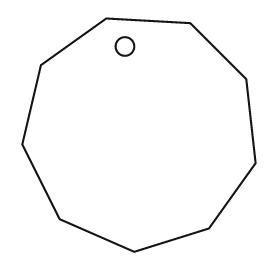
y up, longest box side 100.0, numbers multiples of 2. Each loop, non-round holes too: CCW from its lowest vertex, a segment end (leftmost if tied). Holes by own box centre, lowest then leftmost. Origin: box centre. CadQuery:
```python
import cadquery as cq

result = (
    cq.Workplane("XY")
    .moveTo(-2.0, -50.0)
    .lineTo(30.0, -40.0)
    .lineTo(50.0, -12.0)
    .lineTo(46.0, 24.0)
    .lineTo(22.0, 48.0)
    .lineTo(-14.0, 50.0)
    .lineTo(-42.0, 30.0)
    .lineTo(-50.0, -4.0)
    .lineTo(-34.0, -36.0)
    .close()
    .moveTo(-6.0, 38.0)
    .circle(4.0)
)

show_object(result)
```